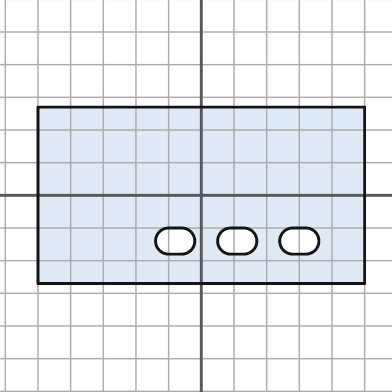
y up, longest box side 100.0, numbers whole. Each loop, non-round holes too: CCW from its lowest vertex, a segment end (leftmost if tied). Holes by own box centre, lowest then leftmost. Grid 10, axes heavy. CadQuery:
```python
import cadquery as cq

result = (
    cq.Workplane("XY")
    .moveTo(-50.0, -27.0)
    .lineTo(50.0, -27.0)
    .lineTo(50.0, 27.0)
    .lineTo(-50.0, 27.0)
    .close()
    .moveTo(-10.0, -18.0)
    .lineTo(-6.0, -18.0)
    .threePointArc((-2.0, -14.0), (-6.0, -10.0))
    .lineTo(-10.0, -10.0)
    .threePointArc((-14.0, -14.0), (-10.0, -18.0))
    .close()
    .moveTo(9.0, -18.0)
    .lineTo(13.0, -18.0)
    .threePointArc((17.0, -14.0), (13.0, -10.0))
    .lineTo(9.0, -10.0)
    .threePointArc((5.0, -14.0), (9.0, -18.0))
    .close()
    .moveTo(28.0, -18.0)
    .lineTo(32.0, -18.0)
    .threePointArc((36.0, -14.0), (32.0, -10.0))
    .lineTo(28.0, -10.0)
    .threePointArc((24.0, -14.0), (28.0, -18.0))
    .close()
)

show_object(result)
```